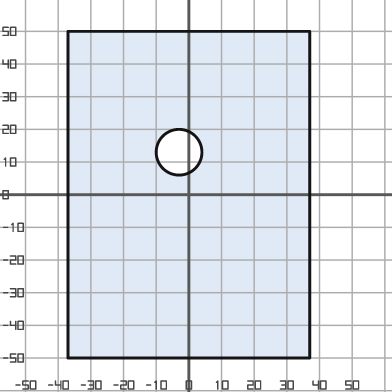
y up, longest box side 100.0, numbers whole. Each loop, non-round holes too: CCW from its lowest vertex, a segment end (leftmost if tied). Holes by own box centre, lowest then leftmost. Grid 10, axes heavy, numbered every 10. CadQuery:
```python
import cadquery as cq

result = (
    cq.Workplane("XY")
    .moveTo(-37.0, -50.0)
    .lineTo(37.0, -50.0)
    .lineTo(37.0, 50.0)
    .lineTo(-37.0, 50.0)
    .close()
    .moveTo(-3.0, 13.0)
    .circle(7.0)
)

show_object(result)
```